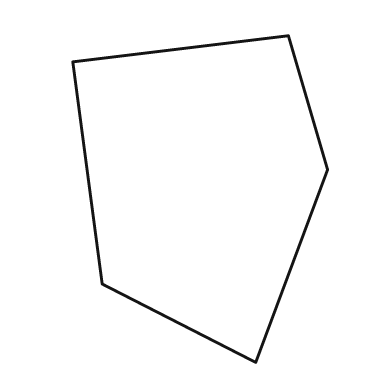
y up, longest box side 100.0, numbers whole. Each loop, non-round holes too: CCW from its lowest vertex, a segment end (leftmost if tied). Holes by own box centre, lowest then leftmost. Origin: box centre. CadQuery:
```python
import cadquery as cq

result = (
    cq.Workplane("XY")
    .moveTo(17.0, -50.0)
    .lineTo(39.0, 9.0)
    .lineTo(27.0, 50.0)
    .lineTo(-39.0, 42.0)
    .lineTo(-30.0, -26.0)
    .close()
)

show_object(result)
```